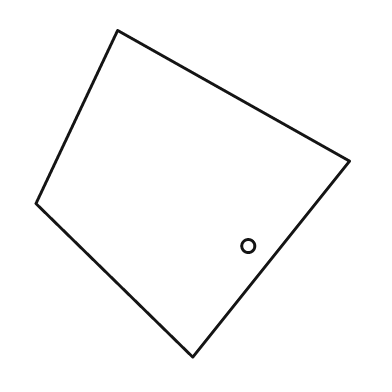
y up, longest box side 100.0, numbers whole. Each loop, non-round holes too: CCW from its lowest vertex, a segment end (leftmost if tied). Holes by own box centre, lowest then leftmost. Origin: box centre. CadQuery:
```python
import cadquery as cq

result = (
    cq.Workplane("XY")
    .moveTo(0.0, -50.0)
    .lineTo(48.0, 10.0)
    .lineTo(-23.0, 50.0)
    .lineTo(-48.0, -3.0)
    .close()
    .moveTo(17.0, -16.0)
    .circle(2.0)
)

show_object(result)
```